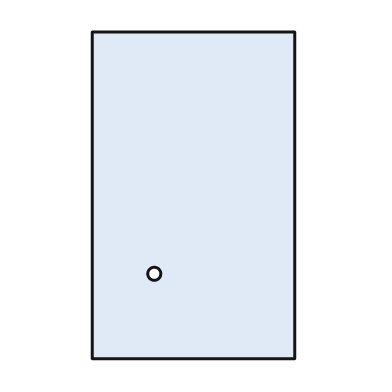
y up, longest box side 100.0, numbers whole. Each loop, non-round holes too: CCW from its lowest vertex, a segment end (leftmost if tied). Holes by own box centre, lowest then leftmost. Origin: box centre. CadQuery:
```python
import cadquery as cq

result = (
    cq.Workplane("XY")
    .moveTo(-31.0, -50.0)
    .lineTo(31.0, -50.0)
    .lineTo(31.0, 50.0)
    .lineTo(-31.0, 50.0)
    .close()
    .moveTo(-12.0, -24.0)
    .circle(2.0)
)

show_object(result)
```